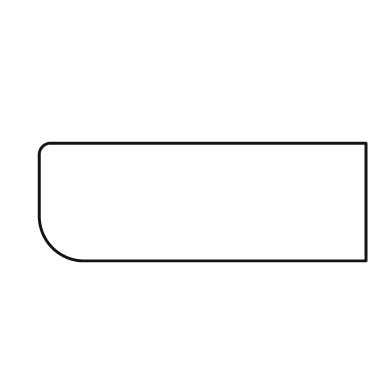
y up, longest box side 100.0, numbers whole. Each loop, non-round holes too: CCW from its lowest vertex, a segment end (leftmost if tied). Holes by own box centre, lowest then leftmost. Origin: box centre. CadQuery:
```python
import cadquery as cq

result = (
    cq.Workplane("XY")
    .moveTo(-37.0, -18.0)
    .lineTo(50.0, -18.0)
    .lineTo(50.0, 18.0)
    .lineTo(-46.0, 18.0)
    .threePointArc((-49.0, 17.0), (-50.0, 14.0))
    .lineTo(-50.0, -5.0)
    .threePointArc((-46.0, -14.0), (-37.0, -18.0))
    .close()
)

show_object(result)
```